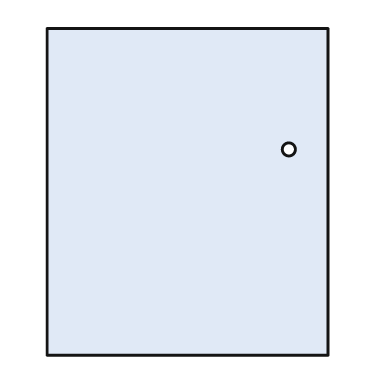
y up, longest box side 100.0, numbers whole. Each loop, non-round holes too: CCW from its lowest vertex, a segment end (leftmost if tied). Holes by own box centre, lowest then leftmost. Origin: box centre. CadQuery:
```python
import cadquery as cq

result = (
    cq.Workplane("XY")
    .moveTo(-43.0, -50.0)
    .lineTo(43.0, -50.0)
    .lineTo(43.0, 50.0)
    .lineTo(-43.0, 50.0)
    .close()
    .moveTo(31.0, 13.0)
    .circle(2.0)
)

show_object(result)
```